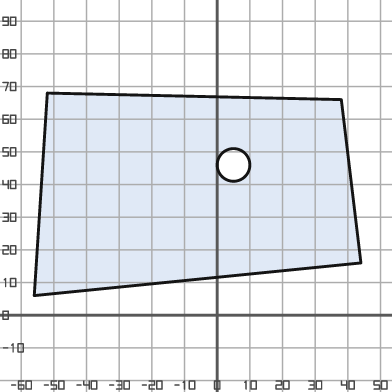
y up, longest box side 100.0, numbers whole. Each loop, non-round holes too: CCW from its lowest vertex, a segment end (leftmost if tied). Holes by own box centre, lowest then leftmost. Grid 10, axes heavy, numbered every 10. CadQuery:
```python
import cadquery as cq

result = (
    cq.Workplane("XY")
    .moveTo(-56.0, 6.0)
    .lineTo(44.0, 16.0)
    .lineTo(38.0, 66.0)
    .lineTo(-52.0, 68.0)
    .close()
    .moveTo(5.0, 46.0)
    .circle(5.0)
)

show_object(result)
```